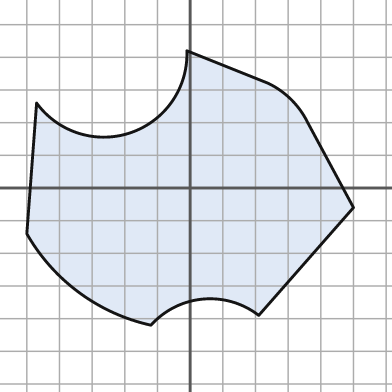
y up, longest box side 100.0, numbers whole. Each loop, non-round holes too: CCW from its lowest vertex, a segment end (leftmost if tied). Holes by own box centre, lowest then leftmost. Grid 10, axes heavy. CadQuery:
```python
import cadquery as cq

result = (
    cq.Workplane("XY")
    .moveTo(-12.0, -42.0)
    .threePointArc((4.0, -34.0), (21.0, -39.0))
    .lineTo(50.0, -6.0)
    .lineTo(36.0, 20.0)
    .threePointArc((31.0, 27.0), (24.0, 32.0))
    .lineTo(-1.0, 42.0)
    .threePointArc((-18.0, 17.0), (-47.0, 26.0))
    .lineTo(-50.0, -14.0)
    .threePointArc((-34.0, -32.0), (-12.0, -42.0))
    .close()
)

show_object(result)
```